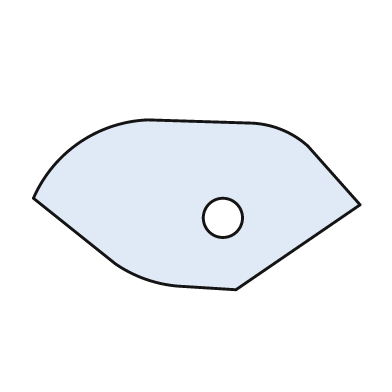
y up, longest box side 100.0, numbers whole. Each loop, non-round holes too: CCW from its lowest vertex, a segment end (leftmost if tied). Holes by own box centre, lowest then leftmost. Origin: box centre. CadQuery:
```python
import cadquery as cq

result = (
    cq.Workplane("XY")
    .moveTo(12.0, -26.0)
    .lineTo(50.0, 0.0)
    .lineTo(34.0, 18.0)
    .threePointArc((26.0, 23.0), (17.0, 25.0))
    .lineTo(-15.0, 26.0)
    .threePointArc((-36.0, 19.0), (-50.0, 2.0))
    .lineTo(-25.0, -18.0)
    .threePointArc((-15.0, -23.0), (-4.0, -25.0))
    .close()
    .moveTo(8.0, -4.0)
    .circle(6.0)
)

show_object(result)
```